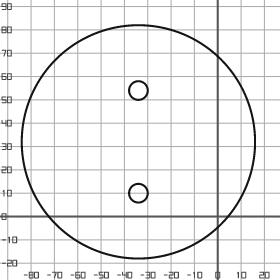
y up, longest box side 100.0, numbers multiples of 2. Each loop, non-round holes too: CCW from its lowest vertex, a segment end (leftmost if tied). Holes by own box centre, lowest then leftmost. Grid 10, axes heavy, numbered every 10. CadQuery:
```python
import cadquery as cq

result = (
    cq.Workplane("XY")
    .moveTo(-34.0, 32.0)
    .circle(50.0)
    .moveTo(-34.0, 10.0)
    .circle(4.0)
    .moveTo(-34.0, 54.0)
    .circle(4.0)
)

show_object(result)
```